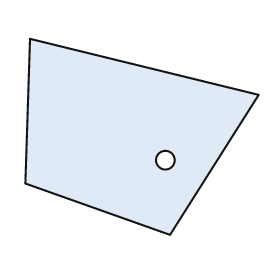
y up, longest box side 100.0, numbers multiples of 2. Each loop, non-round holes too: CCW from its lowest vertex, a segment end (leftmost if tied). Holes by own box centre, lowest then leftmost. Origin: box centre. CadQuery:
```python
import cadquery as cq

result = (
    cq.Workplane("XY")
    .moveTo(12.0, -42.0)
    .lineTo(50.0, 18.0)
    .lineTo(-48.0, 42.0)
    .lineTo(-50.0, -20.0)
    .close()
    .moveTo(10.0, -10.0)
    .circle(4.0)
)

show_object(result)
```